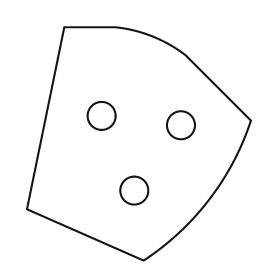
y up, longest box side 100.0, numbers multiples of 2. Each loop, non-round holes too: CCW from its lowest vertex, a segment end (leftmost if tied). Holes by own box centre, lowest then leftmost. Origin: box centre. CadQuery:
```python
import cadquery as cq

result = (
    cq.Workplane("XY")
    .moveTo(2.0, -50.0)
    .threePointArc((30.0, -24.0), (48.0, 10.0))
    .lineTo(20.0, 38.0)
    .threePointArc((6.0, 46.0), (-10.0, 50.0))
    .lineTo(-32.0, 50.0)
    .lineTo(-48.0, -28.0)
    .close()
    .moveTo(-2.0, -20.0)
    .circle(6.0)
    .moveTo(18.0, 8.0)
    .circle(6.0)
    .moveTo(-16.0, 12.0)
    .circle(6.0)
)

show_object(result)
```